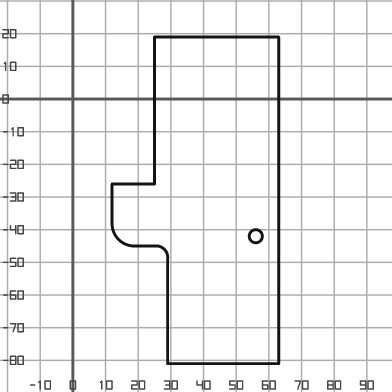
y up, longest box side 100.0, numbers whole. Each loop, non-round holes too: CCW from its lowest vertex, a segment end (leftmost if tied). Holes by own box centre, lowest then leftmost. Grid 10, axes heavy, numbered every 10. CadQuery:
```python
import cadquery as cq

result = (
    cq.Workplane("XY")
    .moveTo(29.0, -81.0)
    .lineTo(63.0, -81.0)
    .lineTo(63.0, 19.0)
    .lineTo(25.0, 19.0)
    .lineTo(25.0, -26.0)
    .lineTo(12.0, -26.0)
    .lineTo(12.0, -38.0)
    .threePointArc((14.0, -43.0), (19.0, -45.0))
    .lineTo(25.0, -45.0)
    .threePointArc((28.0, -46.0), (29.0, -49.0))
    .close()
    .moveTo(56.0, -42.0)
    .circle(2.0)
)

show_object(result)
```